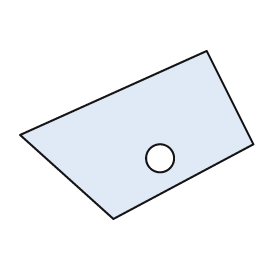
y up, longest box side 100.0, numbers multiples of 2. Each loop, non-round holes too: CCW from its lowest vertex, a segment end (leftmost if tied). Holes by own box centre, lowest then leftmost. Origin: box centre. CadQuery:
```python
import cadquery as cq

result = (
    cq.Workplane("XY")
    .moveTo(-10.0, -36.0)
    .lineTo(50.0, -4.0)
    .lineTo(30.0, 36.0)
    .lineTo(-50.0, 0.0)
    .close()
    .moveTo(10.0, -10.0)
    .circle(6.0)
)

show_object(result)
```